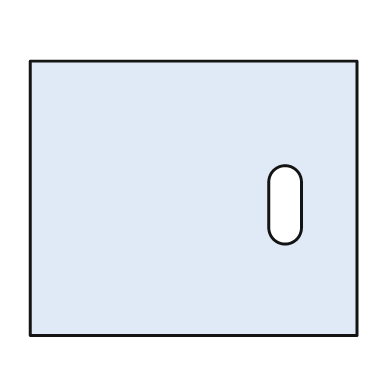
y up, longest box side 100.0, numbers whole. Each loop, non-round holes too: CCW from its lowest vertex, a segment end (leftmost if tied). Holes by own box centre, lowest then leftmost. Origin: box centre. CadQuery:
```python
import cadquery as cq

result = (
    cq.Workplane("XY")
    .moveTo(-50.0, -42.0)
    .lineTo(50.0, -42.0)
    .lineTo(50.0, 42.0)
    .lineTo(-50.0, 42.0)
    .close()
    .moveTo(23.0, -9.0)
    .threePointArc((28.0, -14.0), (33.0, -9.0))
    .lineTo(33.0, 5.0)
    .threePointArc((28.0, 10.0), (23.0, 5.0))
    .close()
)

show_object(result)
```